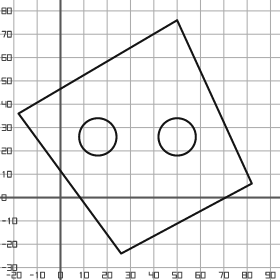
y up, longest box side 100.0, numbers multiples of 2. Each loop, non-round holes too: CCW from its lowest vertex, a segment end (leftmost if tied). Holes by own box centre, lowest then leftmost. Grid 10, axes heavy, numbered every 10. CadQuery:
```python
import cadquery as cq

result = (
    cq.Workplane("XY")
    .moveTo(26.0, -24.0)
    .lineTo(82.0, 6.0)
    .lineTo(50.0, 76.0)
    .lineTo(-18.0, 36.0)
    .close()
    .moveTo(16.0, 26.0)
    .circle(8.0)
    .moveTo(50.0, 26.0)
    .circle(8.0)
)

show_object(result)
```